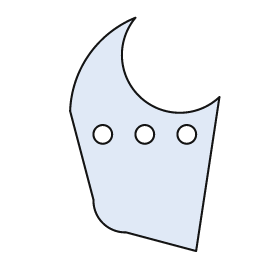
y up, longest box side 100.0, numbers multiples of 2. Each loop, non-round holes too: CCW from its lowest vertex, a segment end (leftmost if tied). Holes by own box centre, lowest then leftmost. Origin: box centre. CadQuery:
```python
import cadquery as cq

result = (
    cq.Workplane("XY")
    .moveTo(22.0, -50.0)
    .lineTo(32.0, 16.0)
    .threePointArc((-2.0, 16.0), (-4.0, 50.0))
    .threePointArc((-24.0, 34.0), (-32.0, 10.0))
    .lineTo(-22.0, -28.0)
    .threePointArc((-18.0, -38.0), (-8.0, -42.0))
    .close()
    .moveTo(-18.0, 0.0)
    .circle(4.0)
    .moveTo(0.0, 0.0)
    .circle(4.0)
    .moveTo(18.0, 0.0)
    .circle(4.0)
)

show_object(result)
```